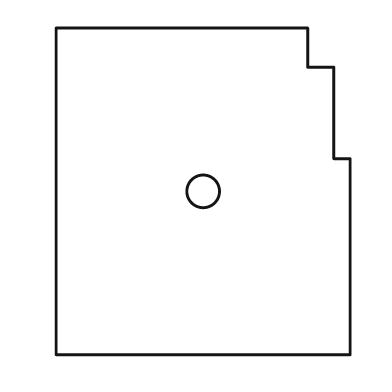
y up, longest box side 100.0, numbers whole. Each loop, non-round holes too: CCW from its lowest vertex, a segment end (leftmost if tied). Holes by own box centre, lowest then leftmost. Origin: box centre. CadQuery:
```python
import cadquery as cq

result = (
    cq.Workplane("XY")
    .moveTo(-45.0, -50.0)
    .lineTo(45.0, -50.0)
    .lineTo(45.0, 10.0)
    .lineTo(40.0, 10.0)
    .lineTo(40.0, 38.0)
    .lineTo(32.0, 38.0)
    .lineTo(32.0, 50.0)
    .lineTo(-45.0, 50.0)
    .close()
    .moveTo(0.0, 0.0)
    .circle(5.0)
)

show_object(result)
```